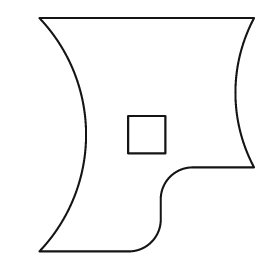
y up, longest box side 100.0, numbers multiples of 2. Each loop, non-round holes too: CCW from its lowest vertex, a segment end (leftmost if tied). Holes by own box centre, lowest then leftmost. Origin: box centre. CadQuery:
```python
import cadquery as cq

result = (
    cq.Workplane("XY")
    .moveTo(-46.0, -50.0)
    .lineTo(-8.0, -50.0)
    .threePointArc((2.0, -46.0), (6.0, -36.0))
    .lineTo(6.0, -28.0)
    .threePointArc((10.0, -18.0), (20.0, -14.0))
    .lineTo(46.0, -14.0)
    .threePointArc((38.0, 18.0), (46.0, 50.0))
    .lineTo(-46.0, 50.0)
    .threePointArc((-26.0, 0.0), (-46.0, -50.0))
    .close()
    .moveTo(-8.0, -8.0)
    .lineTo(8.0, -8.0)
    .lineTo(8.0, 8.0)
    .lineTo(-8.0, 8.0)
    .close()
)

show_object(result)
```